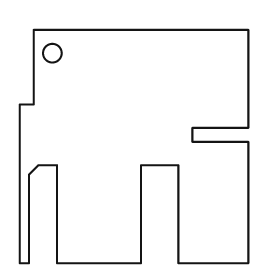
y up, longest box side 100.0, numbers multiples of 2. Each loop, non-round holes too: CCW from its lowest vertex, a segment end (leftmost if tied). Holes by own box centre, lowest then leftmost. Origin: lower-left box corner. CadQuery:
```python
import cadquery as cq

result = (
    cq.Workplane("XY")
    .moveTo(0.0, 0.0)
    .lineTo(4.0, 0.0)
    .lineTo(4.0, 38.0)
    .lineTo(8.0, 42.0)
    .lineTo(16.0, 42.0)
    .lineTo(16.0, 0.0)
    .lineTo(52.0, 0.0)
    .lineTo(52.0, 42.0)
    .lineTo(68.0, 42.0)
    .lineTo(68.0, 0.0)
    .lineTo(98.0, 0.0)
    .lineTo(98.0, 52.0)
    .lineTo(74.0, 52.0)
    .lineTo(74.0, 58.0)
    .lineTo(98.0, 58.0)
    .lineTo(98.0, 100.0)
    .lineTo(6.0, 100.0)
    .lineTo(6.0, 68.0)
    .lineTo(0.0, 68.0)
    .close()
    .moveTo(14.0, 90.0)
    .circle(4.0)
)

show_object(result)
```